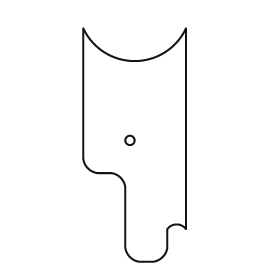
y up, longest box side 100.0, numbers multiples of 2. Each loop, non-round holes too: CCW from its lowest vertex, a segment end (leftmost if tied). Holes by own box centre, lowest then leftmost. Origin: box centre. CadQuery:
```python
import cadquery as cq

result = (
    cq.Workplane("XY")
    .moveTo(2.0, -50.0)
    .lineTo(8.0, -50.0)
    .threePointArc((12.0, -48.0), (14.0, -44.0))
    .lineTo(14.0, -36.0)
    .threePointArc((18.0, -34.0), (22.0, -36.0))
    .lineTo(22.0, 50.0)
    .threePointArc((0.0, 36.0), (-22.0, 50.0))
    .lineTo(-22.0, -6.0)
    .threePointArc((-20.0, -10.0), (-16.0, -12.0))
    .lineTo(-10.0, -12.0)
    .threePointArc((-6.0, -14.0), (-4.0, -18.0))
    .lineTo(-4.0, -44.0)
    .threePointArc((-2.0, -48.0), (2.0, -50.0))
    .close()
    .moveTo(-2.0, 2.0)
    .circle(2.0)
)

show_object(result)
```